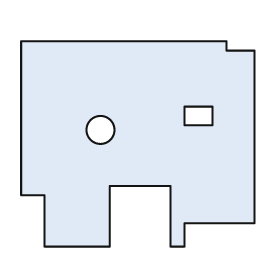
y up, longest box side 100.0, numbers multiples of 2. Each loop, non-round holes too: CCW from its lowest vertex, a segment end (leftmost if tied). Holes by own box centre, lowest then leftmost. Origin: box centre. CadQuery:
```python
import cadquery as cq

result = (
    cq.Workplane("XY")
    .moveTo(-40.0, -44.0)
    .lineTo(-12.0, -44.0)
    .lineTo(-12.0, -18.0)
    .lineTo(14.0, -18.0)
    .lineTo(14.0, -44.0)
    .lineTo(20.0, -44.0)
    .lineTo(20.0, -34.0)
    .lineTo(50.0, -34.0)
    .lineTo(50.0, 40.0)
    .lineTo(38.0, 40.0)
    .lineTo(38.0, 44.0)
    .lineTo(-50.0, 44.0)
    .lineTo(-50.0, -22.0)
    .lineTo(-40.0, -22.0)
    .close()
    .moveTo(-16.0, 6.0)
    .circle(6.0)
    .moveTo(20.0, 8.0)
    .lineTo(32.0, 8.0)
    .lineTo(32.0, 16.0)
    .lineTo(20.0, 16.0)
    .close()
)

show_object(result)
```